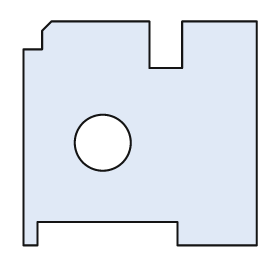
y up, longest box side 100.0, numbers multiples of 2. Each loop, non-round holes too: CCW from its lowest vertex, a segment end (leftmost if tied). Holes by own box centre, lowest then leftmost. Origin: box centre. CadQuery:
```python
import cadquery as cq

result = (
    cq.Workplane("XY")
    .moveTo(-50.0, -48.0)
    .lineTo(-44.0, -48.0)
    .lineTo(-44.0, -38.0)
    .lineTo(16.0, -38.0)
    .lineTo(16.0, -48.0)
    .lineTo(50.0, -48.0)
    .lineTo(50.0, 48.0)
    .lineTo(18.0, 48.0)
    .lineTo(18.0, 28.0)
    .lineTo(4.0, 28.0)
    .lineTo(4.0, 48.0)
    .lineTo(-38.0, 48.0)
    .lineTo(-42.0, 44.0)
    .lineTo(-42.0, 36.0)
    .lineTo(-50.0, 36.0)
    .close()
    .moveTo(-16.0, -4.0)
    .circle(12.0)
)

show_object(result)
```